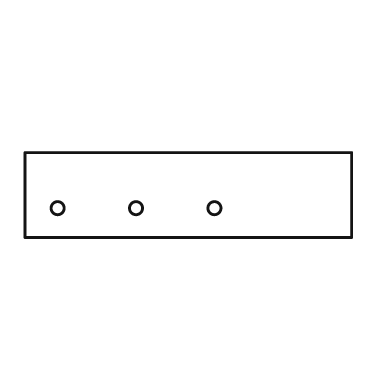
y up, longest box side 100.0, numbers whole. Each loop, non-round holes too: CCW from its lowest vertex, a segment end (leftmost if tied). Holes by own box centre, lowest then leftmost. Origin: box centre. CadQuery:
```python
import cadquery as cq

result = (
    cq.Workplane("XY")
    .moveTo(-50.0, -13.0)
    .lineTo(50.0, -13.0)
    .lineTo(50.0, 13.0)
    .lineTo(-50.0, 13.0)
    .close()
    .moveTo(-40.0, -4.0)
    .circle(2.0)
    .moveTo(-16.0, -4.0)
    .circle(2.0)
    .moveTo(8.0, -4.0)
    .circle(2.0)
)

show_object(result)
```